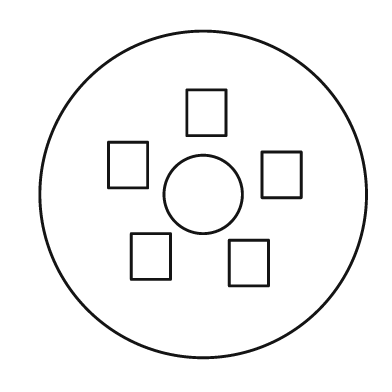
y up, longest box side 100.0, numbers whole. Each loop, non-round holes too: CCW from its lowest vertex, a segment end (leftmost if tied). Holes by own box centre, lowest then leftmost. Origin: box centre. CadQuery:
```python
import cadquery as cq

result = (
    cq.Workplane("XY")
    .moveTo(0.0, 0.0)
    .circle(50.0)
    .moveTo(8.0, -28.0)
    .lineTo(20.0, -28.0)
    .lineTo(20.0, -14.0)
    .lineTo(8.0, -14.0)
    .close()
    .moveTo(-22.0, -26.0)
    .lineTo(-10.0, -26.0)
    .lineTo(-10.0, -12.0)
    .lineTo(-22.0, -12.0)
    .close()
    .moveTo(0.0, 0.0)
    .circle(12.0)
    .moveTo(18.0, -1.0)
    .lineTo(30.0, -1.0)
    .lineTo(30.0, 13.0)
    .lineTo(18.0, 13.0)
    .close()
    .moveTo(-29.0, 2.0)
    .lineTo(-17.0, 2.0)
    .lineTo(-17.0, 16.0)
    .lineTo(-29.0, 16.0)
    .close()
    .moveTo(-5.0, 18.0)
    .lineTo(7.0, 18.0)
    .lineTo(7.0, 32.0)
    .lineTo(-5.0, 32.0)
    .close()
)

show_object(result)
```